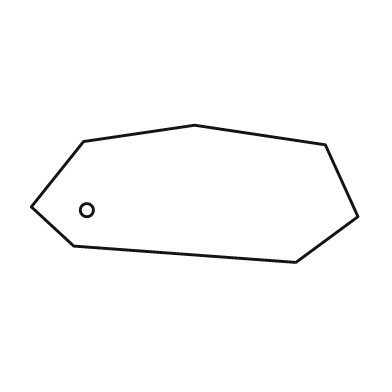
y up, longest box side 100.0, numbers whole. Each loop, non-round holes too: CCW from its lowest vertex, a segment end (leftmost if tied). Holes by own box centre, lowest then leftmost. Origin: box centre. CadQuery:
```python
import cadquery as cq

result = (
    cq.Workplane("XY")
    .moveTo(31.0, -21.0)
    .lineTo(50.0, -7.0)
    .lineTo(40.0, 15.0)
    .lineTo(0.0, 21.0)
    .lineTo(-34.0, 16.0)
    .lineTo(-50.0, -4.0)
    .lineTo(-37.0, -16.0)
    .close()
    .moveTo(-33.0, -5.0)
    .circle(2.0)
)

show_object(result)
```